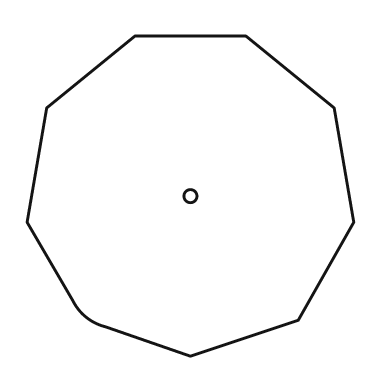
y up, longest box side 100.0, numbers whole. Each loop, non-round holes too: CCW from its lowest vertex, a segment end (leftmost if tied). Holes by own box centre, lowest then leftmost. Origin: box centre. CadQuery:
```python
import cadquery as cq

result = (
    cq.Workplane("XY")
    .moveTo(0.0, -49.0)
    .lineTo(33.0, -38.0)
    .lineTo(50.0, -8.0)
    .lineTo(44.0, 27.0)
    .lineTo(17.0, 49.0)
    .lineTo(-17.0, 49.0)
    .lineTo(-44.0, 27.0)
    .lineTo(-50.0, -8.0)
    .lineTo(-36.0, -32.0)
    .threePointArc((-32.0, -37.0), (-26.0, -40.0))
    .close()
    .moveTo(0.0, 0.0)
    .circle(2.0)
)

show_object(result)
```